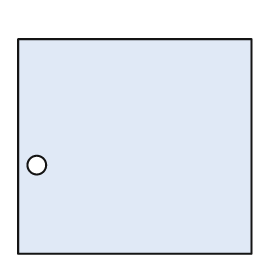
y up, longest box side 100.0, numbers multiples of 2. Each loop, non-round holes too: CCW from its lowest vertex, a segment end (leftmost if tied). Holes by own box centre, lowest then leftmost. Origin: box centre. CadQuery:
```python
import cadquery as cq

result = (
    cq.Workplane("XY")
    .moveTo(-50.0, -46.0)
    .lineTo(50.0, -46.0)
    .lineTo(50.0, 46.0)
    .lineTo(-50.0, 46.0)
    .close()
    .moveTo(-42.0, -8.0)
    .circle(4.0)
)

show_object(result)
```